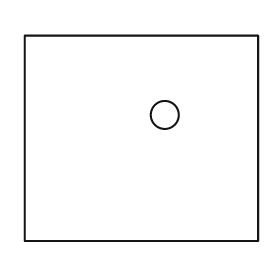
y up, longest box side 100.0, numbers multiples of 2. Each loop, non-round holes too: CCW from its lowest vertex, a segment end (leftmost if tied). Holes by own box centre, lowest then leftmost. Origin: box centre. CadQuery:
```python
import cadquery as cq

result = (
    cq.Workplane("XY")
    .moveTo(-50.0, -44.0)
    .lineTo(50.0, -44.0)
    .lineTo(50.0, 44.0)
    .lineTo(-50.0, 44.0)
    .close()
    .moveTo(10.0, 10.0)
    .circle(6.0)
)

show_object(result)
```